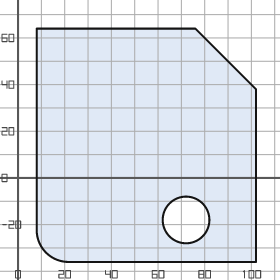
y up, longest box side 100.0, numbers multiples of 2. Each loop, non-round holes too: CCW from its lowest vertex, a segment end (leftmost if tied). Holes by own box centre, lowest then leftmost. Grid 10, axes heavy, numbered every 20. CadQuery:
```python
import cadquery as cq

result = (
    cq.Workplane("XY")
    .moveTo(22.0, -36.0)
    .lineTo(102.0, -36.0)
    .lineTo(102.0, 38.0)
    .lineTo(76.0, 64.0)
    .lineTo(8.0, 64.0)
    .lineTo(8.0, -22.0)
    .threePointArc((12.0, -32.0), (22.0, -36.0))
    .close()
    .moveTo(72.0, -18.0)
    .circle(10.0)
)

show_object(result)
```